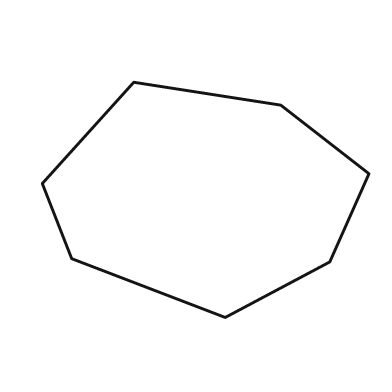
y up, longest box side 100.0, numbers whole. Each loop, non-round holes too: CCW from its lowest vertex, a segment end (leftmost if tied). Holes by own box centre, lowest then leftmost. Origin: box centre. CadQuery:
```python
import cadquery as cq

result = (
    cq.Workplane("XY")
    .moveTo(6.0, -36.0)
    .lineTo(38.0, -19.0)
    .lineTo(50.0, 8.0)
    .lineTo(23.0, 29.0)
    .lineTo(-22.0, 36.0)
    .lineTo(-50.0, 5.0)
    .lineTo(-41.0, -18.0)
    .close()
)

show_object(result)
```